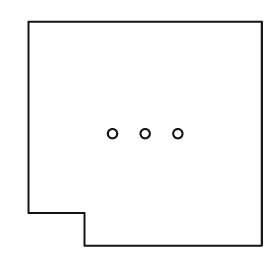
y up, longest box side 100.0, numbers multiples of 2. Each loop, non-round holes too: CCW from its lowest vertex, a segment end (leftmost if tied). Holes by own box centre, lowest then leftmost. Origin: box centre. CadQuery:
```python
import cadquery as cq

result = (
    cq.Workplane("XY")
    .moveTo(-26.0, -48.0)
    .lineTo(50.0, -48.0)
    .lineTo(50.0, 48.0)
    .lineTo(-50.0, 48.0)
    .lineTo(-50.0, -34.0)
    .lineTo(-26.0, -34.0)
    .close()
    .moveTo(-14.0, 0.0)
    .circle(2.0)
    .moveTo(0.0, 0.0)
    .circle(2.0)
    .moveTo(14.0, 0.0)
    .circle(2.0)
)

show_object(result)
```